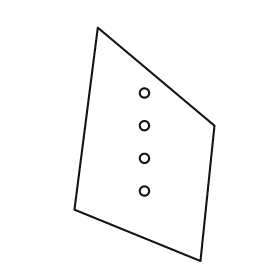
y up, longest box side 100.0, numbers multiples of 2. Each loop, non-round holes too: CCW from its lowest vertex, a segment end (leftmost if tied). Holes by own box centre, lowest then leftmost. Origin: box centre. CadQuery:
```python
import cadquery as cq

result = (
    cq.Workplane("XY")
    .moveTo(24.0, -50.0)
    .lineTo(30.0, 8.0)
    .lineTo(-20.0, 50.0)
    .lineTo(-30.0, -28.0)
    .close()
    .moveTo(0.0, -20.0)
    .circle(2.0)
    .moveTo(0.0, -6.0)
    .circle(2.0)
    .moveTo(0.0, 8.0)
    .circle(2.0)
    .moveTo(0.0, 22.0)
    .circle(2.0)
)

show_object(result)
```